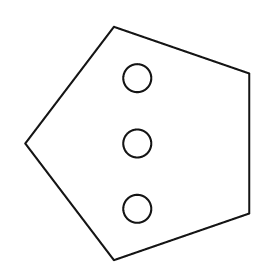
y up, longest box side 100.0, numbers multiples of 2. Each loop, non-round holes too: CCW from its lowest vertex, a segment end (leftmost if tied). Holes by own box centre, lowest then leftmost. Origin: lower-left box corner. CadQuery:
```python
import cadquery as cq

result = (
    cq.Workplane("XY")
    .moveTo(38.0, 0.0)
    .lineTo(96.0, 20.0)
    .lineTo(96.0, 80.0)
    .lineTo(38.0, 100.0)
    .lineTo(0.0, 50.0)
    .close()
    .moveTo(48.0, 22.0)
    .circle(6.0)
    .moveTo(48.0, 50.0)
    .circle(6.0)
    .moveTo(48.0, 78.0)
    .circle(6.0)
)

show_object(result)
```